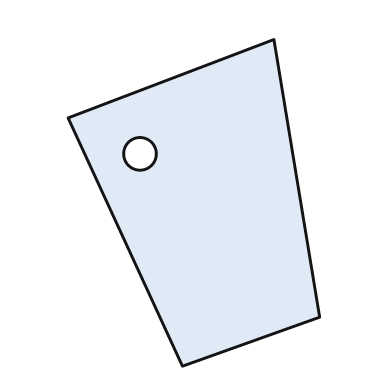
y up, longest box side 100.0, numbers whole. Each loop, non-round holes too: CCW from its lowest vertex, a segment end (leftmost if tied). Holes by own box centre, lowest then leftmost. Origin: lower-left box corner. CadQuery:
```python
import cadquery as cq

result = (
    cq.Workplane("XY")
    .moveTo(35.0, 0.0)
    .lineTo(77.0, 15.0)
    .lineTo(63.0, 100.0)
    .lineTo(0.0, 76.0)
    .close()
    .moveTo(22.0, 65.0)
    .circle(5.0)
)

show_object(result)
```